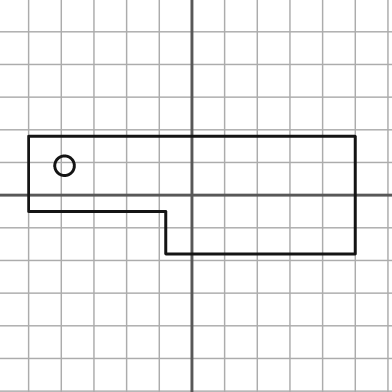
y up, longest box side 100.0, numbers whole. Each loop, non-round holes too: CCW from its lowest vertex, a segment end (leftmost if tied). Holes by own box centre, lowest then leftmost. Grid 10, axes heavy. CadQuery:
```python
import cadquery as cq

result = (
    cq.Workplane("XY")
    .moveTo(-8.0, -18.0)
    .lineTo(50.0, -18.0)
    .lineTo(50.0, 18.0)
    .lineTo(-50.0, 18.0)
    .lineTo(-50.0, -5.0)
    .lineTo(-8.0, -5.0)
    .close()
    .moveTo(-39.0, 9.0)
    .circle(3.0)
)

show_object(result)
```